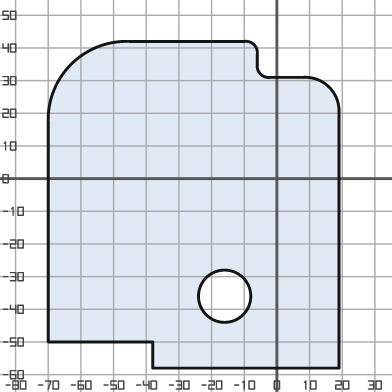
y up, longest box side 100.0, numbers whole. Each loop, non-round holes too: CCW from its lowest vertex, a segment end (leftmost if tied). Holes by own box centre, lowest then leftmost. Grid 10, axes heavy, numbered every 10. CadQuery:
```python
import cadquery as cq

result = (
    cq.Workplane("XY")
    .moveTo(-38.0, -58.0)
    .lineTo(19.0, -58.0)
    .lineTo(19.0, 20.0)
    .threePointArc((16.0, 28.0), (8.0, 31.0))
    .lineTo(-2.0, 31.0)
    .threePointArc((-5.0, 32.0), (-6.0, 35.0))
    .lineTo(-6.0, 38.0)
    .threePointArc((-7.0, 41.0), (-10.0, 42.0))
    .lineTo(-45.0, 42.0)
    .threePointArc((-63.0, 35.0), (-70.0, 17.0))
    .lineTo(-70.0, -50.0)
    .lineTo(-38.0, -50.0)
    .close()
    .moveTo(-16.0, -36.0)
    .circle(8.0)
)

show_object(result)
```